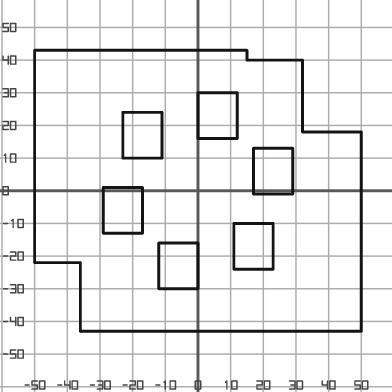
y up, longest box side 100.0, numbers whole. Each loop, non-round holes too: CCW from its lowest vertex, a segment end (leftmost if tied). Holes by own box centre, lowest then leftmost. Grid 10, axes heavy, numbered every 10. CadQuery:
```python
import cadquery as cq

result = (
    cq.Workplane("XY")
    .moveTo(-36.0, -43.0)
    .lineTo(50.0, -43.0)
    .lineTo(50.0, 18.0)
    .lineTo(32.0, 18.0)
    .lineTo(32.0, 40.0)
    .lineTo(15.0, 40.0)
    .lineTo(15.0, 43.0)
    .lineTo(-50.0, 43.0)
    .lineTo(-50.0, -22.0)
    .lineTo(-36.0, -22.0)
    .close()
    .moveTo(-12.0, -30.0)
    .lineTo(0.0, -30.0)
    .lineTo(0.0, -16.0)
    .lineTo(-12.0, -16.0)
    .close()
    .moveTo(11.0, -24.0)
    .lineTo(23.0, -24.0)
    .lineTo(23.0, -10.0)
    .lineTo(11.0, -10.0)
    .close()
    .moveTo(-29.0, -13.0)
    .lineTo(-17.0, -13.0)
    .lineTo(-17.0, 1.0)
    .lineTo(-29.0, 1.0)
    .close()
    .moveTo(17.0, -1.0)
    .lineTo(29.0, -1.0)
    .lineTo(29.0, 13.0)
    .lineTo(17.0, 13.0)
    .close()
    .moveTo(-23.0, 10.0)
    .lineTo(-11.0, 10.0)
    .lineTo(-11.0, 24.0)
    .lineTo(-23.0, 24.0)
    .close()
    .moveTo(0.0, 16.0)
    .lineTo(12.0, 16.0)
    .lineTo(12.0, 30.0)
    .lineTo(0.0, 30.0)
    .close()
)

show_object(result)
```